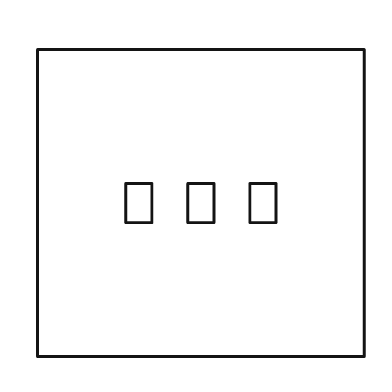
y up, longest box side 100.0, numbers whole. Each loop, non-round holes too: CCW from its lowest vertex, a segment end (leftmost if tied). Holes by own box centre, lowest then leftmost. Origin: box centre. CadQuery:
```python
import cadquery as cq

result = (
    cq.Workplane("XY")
    .moveTo(-50.0, -47.0)
    .lineTo(50.0, -47.0)
    .lineTo(50.0, 47.0)
    .lineTo(-50.0, 47.0)
    .close()
    .moveTo(-23.0, -6.0)
    .lineTo(-15.0, -6.0)
    .lineTo(-15.0, 6.0)
    .lineTo(-23.0, 6.0)
    .close()
    .moveTo(-4.0, -6.0)
    .lineTo(4.0, -6.0)
    .lineTo(4.0, 6.0)
    .lineTo(-4.0, 6.0)
    .close()
    .moveTo(15.0, -6.0)
    .lineTo(23.0, -6.0)
    .lineTo(23.0, 6.0)
    .lineTo(15.0, 6.0)
    .close()
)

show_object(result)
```